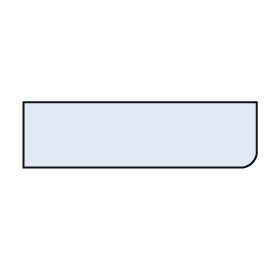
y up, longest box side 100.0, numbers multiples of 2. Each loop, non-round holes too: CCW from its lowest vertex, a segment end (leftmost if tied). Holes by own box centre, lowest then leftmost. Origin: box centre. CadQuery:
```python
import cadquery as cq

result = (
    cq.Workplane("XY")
    .moveTo(-50.0, -14.0)
    .lineTo(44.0, -14.0)
    .threePointArc((48.0, -12.0), (50.0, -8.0))
    .lineTo(50.0, 14.0)
    .lineTo(-50.0, 14.0)
    .close()
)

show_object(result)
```